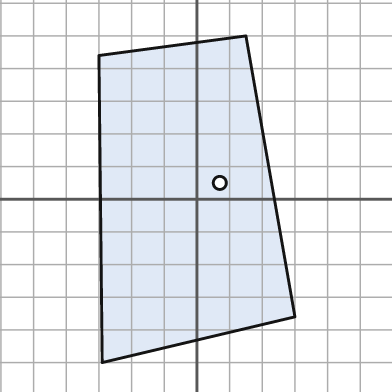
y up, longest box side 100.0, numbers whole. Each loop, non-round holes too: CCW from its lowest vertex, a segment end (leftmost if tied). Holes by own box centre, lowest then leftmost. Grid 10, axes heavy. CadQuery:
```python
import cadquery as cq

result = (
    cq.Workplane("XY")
    .moveTo(-29.0, -50.0)
    .lineTo(30.0, -36.0)
    .lineTo(15.0, 50.0)
    .lineTo(-30.0, 44.0)
    .close()
    .moveTo(7.0, 5.0)
    .circle(2.0)
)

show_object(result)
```